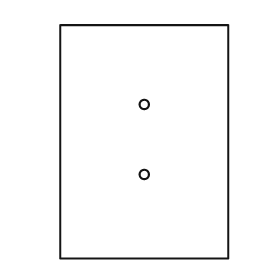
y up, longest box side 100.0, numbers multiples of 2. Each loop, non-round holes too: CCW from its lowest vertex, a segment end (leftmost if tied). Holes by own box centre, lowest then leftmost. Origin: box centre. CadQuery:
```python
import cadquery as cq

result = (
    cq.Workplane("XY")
    .moveTo(-36.0, -50.0)
    .lineTo(36.0, -50.0)
    .lineTo(36.0, 50.0)
    .lineTo(-36.0, 50.0)
    .close()
    .moveTo(0.0, -14.0)
    .circle(2.0)
    .moveTo(0.0, 16.0)
    .circle(2.0)
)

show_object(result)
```